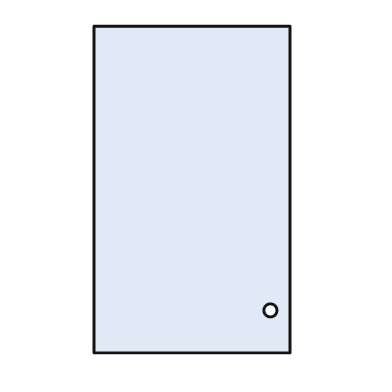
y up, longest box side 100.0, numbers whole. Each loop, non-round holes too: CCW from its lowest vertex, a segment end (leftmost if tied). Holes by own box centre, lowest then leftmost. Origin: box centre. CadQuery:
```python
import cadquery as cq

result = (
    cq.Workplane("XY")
    .moveTo(-30.0, -50.0)
    .lineTo(30.0, -50.0)
    .lineTo(30.0, 50.0)
    .lineTo(-30.0, 50.0)
    .close()
    .moveTo(24.0, -37.0)
    .circle(2.0)
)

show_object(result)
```